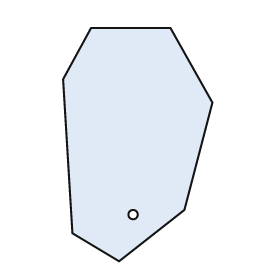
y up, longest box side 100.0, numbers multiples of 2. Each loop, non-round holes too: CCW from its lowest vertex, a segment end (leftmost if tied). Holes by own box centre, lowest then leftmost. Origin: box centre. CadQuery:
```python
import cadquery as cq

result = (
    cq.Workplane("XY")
    .moveTo(-8.0, -50.0)
    .lineTo(20.0, -28.0)
    .lineTo(32.0, 18.0)
    .lineTo(14.0, 50.0)
    .lineTo(-20.0, 50.0)
    .lineTo(-32.0, 28.0)
    .lineTo(-28.0, -38.0)
    .close()
    .moveTo(-2.0, -30.0)
    .circle(2.0)
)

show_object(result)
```